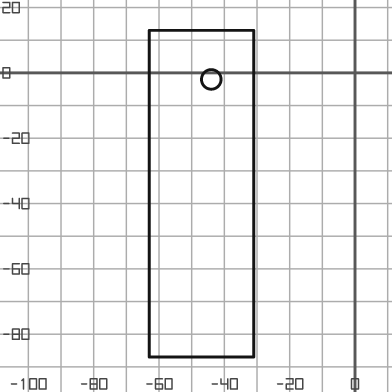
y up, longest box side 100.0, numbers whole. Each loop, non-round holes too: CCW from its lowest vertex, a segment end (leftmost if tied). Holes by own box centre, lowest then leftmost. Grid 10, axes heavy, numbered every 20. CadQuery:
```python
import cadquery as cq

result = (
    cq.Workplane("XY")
    .moveTo(-63.0, -87.0)
    .lineTo(-31.0, -87.0)
    .lineTo(-31.0, 13.0)
    .lineTo(-63.0, 13.0)
    .close()
    .moveTo(-44.0, -2.0)
    .circle(3.0)
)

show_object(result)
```